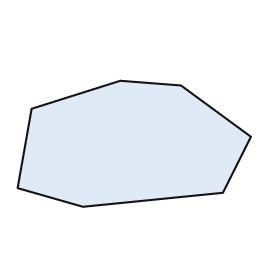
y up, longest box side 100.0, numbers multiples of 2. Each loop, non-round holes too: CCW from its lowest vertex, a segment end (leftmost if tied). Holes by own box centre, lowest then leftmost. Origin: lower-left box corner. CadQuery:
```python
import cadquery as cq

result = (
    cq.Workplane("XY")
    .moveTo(28.0, 0.0)
    .lineTo(88.0, 6.0)
    .lineTo(100.0, 30.0)
    .lineTo(70.0, 52.0)
    .lineTo(44.0, 54.0)
    .lineTo(6.0, 42.0)
    .lineTo(0.0, 8.0)
    .close()
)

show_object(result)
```